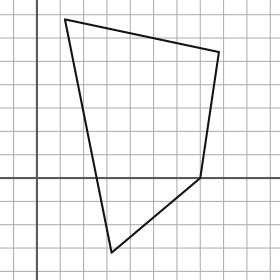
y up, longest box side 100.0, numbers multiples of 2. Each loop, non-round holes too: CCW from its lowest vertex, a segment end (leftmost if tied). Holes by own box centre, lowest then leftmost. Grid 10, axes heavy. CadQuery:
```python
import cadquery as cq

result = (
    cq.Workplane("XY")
    .moveTo(32.0, -32.0)
    .lineTo(70.0, 0.0)
    .lineTo(78.0, 54.0)
    .lineTo(12.0, 68.0)
    .close()
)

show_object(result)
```